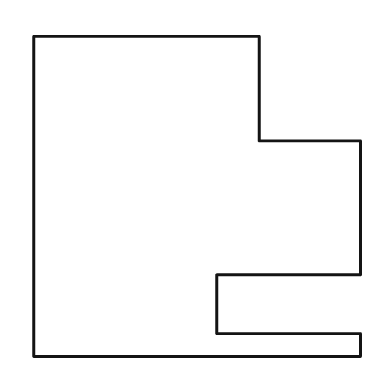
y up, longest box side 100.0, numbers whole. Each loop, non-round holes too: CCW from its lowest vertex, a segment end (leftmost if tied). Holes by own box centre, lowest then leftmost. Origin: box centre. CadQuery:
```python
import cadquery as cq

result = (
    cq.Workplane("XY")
    .moveTo(-50.0, -49.0)
    .lineTo(50.0, -49.0)
    .lineTo(50.0, -42.0)
    .lineTo(6.0, -42.0)
    .lineTo(6.0, -24.0)
    .lineTo(50.0, -24.0)
    .lineTo(50.0, 17.0)
    .lineTo(19.0, 17.0)
    .lineTo(19.0, 49.0)
    .lineTo(-50.0, 49.0)
    .close()
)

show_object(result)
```